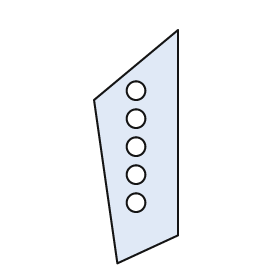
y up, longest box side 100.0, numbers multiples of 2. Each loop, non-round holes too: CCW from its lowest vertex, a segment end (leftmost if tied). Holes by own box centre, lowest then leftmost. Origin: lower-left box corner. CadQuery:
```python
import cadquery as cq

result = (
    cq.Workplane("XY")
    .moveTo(10.0, 0.0)
    .lineTo(36.0, 12.0)
    .lineTo(36.0, 100.0)
    .lineTo(0.0, 70.0)
    .close()
    .moveTo(18.0, 26.0)
    .circle(4.0)
    .moveTo(18.0, 38.0)
    .circle(4.0)
    .moveTo(18.0, 50.0)
    .circle(4.0)
    .moveTo(18.0, 62.0)
    .circle(4.0)
    .moveTo(18.0, 74.0)
    .circle(4.0)
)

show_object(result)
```